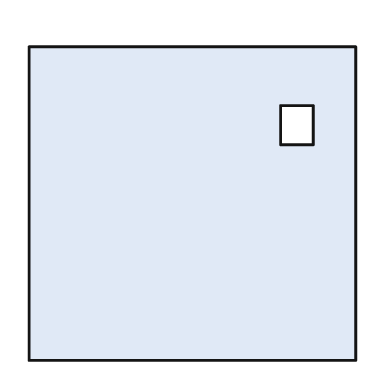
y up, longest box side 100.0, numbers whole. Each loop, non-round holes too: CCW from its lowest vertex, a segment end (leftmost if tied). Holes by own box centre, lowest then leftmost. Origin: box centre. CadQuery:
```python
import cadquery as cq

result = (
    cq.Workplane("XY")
    .moveTo(-50.0, -48.0)
    .lineTo(50.0, -48.0)
    .lineTo(50.0, 48.0)
    .lineTo(-50.0, 48.0)
    .close()
    .moveTo(27.0, 18.0)
    .lineTo(37.0, 18.0)
    .lineTo(37.0, 30.0)
    .lineTo(27.0, 30.0)
    .close()
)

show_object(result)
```